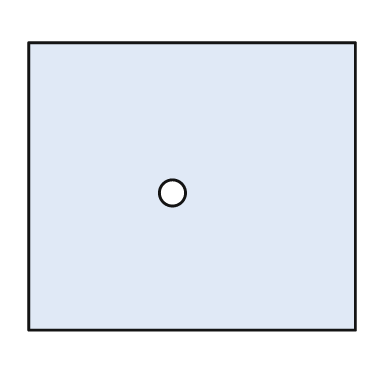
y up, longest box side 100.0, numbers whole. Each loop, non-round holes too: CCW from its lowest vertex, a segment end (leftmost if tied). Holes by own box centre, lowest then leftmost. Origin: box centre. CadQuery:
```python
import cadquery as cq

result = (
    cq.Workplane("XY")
    .moveTo(-50.0, -44.0)
    .lineTo(50.0, -44.0)
    .lineTo(50.0, 44.0)
    .lineTo(-50.0, 44.0)
    .close()
    .moveTo(-6.0, -2.0)
    .circle(4.0)
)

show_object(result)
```